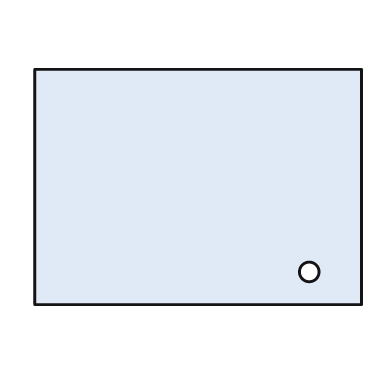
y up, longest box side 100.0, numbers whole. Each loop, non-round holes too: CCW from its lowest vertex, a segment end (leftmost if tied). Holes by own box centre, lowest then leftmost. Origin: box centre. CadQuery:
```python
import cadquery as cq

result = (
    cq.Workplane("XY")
    .moveTo(-50.0, -36.0)
    .lineTo(50.0, -36.0)
    .lineTo(50.0, 36.0)
    .lineTo(-50.0, 36.0)
    .close()
    .moveTo(34.0, -26.0)
    .circle(3.0)
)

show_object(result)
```